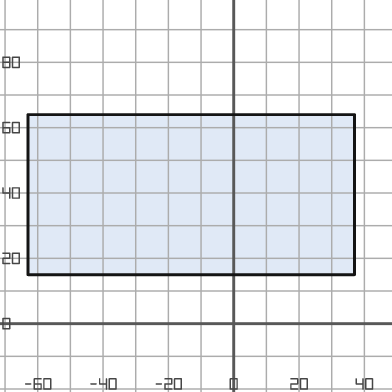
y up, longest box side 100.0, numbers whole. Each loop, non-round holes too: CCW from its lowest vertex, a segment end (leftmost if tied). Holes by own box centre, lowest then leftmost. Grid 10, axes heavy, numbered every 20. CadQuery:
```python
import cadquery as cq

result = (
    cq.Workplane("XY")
    .moveTo(-63.0, 15.0)
    .lineTo(37.0, 15.0)
    .lineTo(37.0, 64.0)
    .lineTo(-63.0, 64.0)
    .close()
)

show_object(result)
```